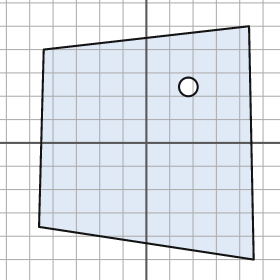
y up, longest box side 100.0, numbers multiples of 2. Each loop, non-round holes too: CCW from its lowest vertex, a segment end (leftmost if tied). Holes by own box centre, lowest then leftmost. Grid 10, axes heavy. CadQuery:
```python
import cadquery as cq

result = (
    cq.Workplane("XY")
    .moveTo(46.0, -50.0)
    .lineTo(44.0, 50.0)
    .lineTo(-44.0, 40.0)
    .lineTo(-46.0, -36.0)
    .close()
    .moveTo(18.0, 24.0)
    .circle(4.0)
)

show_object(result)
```